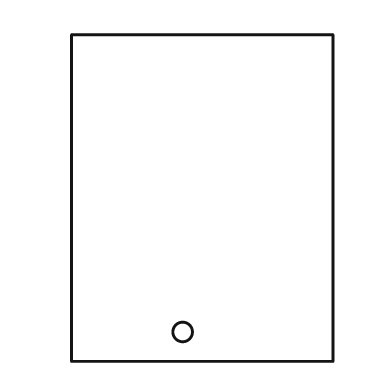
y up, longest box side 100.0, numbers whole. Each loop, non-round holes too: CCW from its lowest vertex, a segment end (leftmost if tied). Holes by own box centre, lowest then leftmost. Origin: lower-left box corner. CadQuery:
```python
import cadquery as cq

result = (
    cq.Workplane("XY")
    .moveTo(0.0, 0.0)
    .lineTo(80.0, 0.0)
    .lineTo(80.0, 100.0)
    .lineTo(0.0, 100.0)
    .close()
    .moveTo(34.0, 9.0)
    .circle(3.0)
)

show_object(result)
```